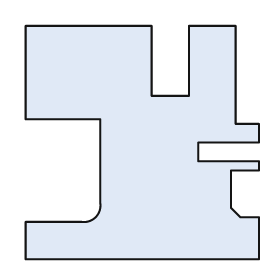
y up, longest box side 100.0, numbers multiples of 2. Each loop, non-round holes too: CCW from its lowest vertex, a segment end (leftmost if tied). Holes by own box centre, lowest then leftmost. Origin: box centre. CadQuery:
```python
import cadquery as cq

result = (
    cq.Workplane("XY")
    .moveTo(-50.0, -50.0)
    .lineTo(50.0, -50.0)
    .lineTo(50.0, -32.0)
    .lineTo(42.0, -32.0)
    .lineTo(38.0, -28.0)
    .lineTo(38.0, -12.0)
    .lineTo(50.0, -12.0)
    .lineTo(50.0, -8.0)
    .lineTo(24.0, -8.0)
    .lineTo(24.0, 0.0)
    .lineTo(50.0, 0.0)
    .lineTo(50.0, 8.0)
    .lineTo(40.0, 8.0)
    .lineTo(40.0, 50.0)
    .lineTo(20.0, 50.0)
    .lineTo(20.0, 20.0)
    .lineTo(4.0, 20.0)
    .lineTo(4.0, 50.0)
    .lineTo(-50.0, 50.0)
    .lineTo(-50.0, 10.0)
    .lineTo(-18.0, 10.0)
    .lineTo(-18.0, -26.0)
    .threePointArc((-20.0, -32.0), (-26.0, -34.0))
    .lineTo(-50.0, -34.0)
    .close()
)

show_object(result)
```